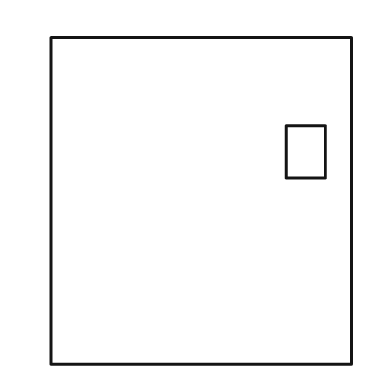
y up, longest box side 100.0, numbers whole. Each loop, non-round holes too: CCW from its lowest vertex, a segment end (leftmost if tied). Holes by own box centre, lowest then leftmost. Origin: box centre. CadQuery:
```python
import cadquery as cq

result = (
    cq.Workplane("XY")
    .moveTo(-46.0, -50.0)
    .lineTo(46.0, -50.0)
    .lineTo(46.0, 50.0)
    .lineTo(-46.0, 50.0)
    .close()
    .moveTo(26.0, 7.0)
    .lineTo(38.0, 7.0)
    .lineTo(38.0, 23.0)
    .lineTo(26.0, 23.0)
    .close()
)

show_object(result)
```